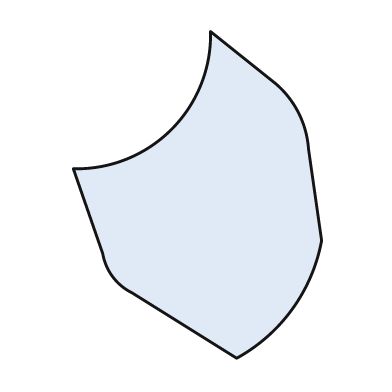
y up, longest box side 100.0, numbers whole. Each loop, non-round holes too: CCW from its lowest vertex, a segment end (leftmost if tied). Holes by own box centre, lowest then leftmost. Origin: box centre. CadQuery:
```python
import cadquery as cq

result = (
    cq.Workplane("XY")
    .moveTo(12.0, -50.0)
    .threePointArc((29.0, -35.0), (38.0, -14.0))
    .lineTo(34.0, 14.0)
    .threePointArc((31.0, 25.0), (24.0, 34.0))
    .lineTo(4.0, 50.0)
    .threePointArc((-8.0, 20.0), (-38.0, 8.0))
    .lineTo(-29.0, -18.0)
    .threePointArc((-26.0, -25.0), (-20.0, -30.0))
    .close()
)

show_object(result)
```